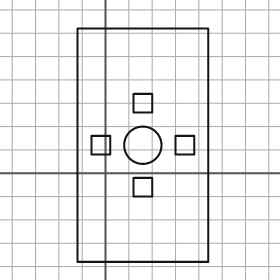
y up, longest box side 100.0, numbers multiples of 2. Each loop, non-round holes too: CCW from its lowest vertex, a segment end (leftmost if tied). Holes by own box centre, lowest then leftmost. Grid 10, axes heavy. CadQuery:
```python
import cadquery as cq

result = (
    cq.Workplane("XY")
    .moveTo(-12.0, -38.0)
    .lineTo(44.0, -38.0)
    .lineTo(44.0, 62.0)
    .lineTo(-12.0, 62.0)
    .close()
    .moveTo(12.0, -10.0)
    .lineTo(20.0, -10.0)
    .lineTo(20.0, -2.0)
    .lineTo(12.0, -2.0)
    .close()
    .moveTo(-6.0, 8.0)
    .lineTo(2.0, 8.0)
    .lineTo(2.0, 16.0)
    .lineTo(-6.0, 16.0)
    .close()
    .moveTo(16.0, 12.0)
    .circle(8.0)
    .moveTo(30.0, 8.0)
    .lineTo(38.0, 8.0)
    .lineTo(38.0, 16.0)
    .lineTo(30.0, 16.0)
    .close()
    .moveTo(12.0, 26.0)
    .lineTo(20.0, 26.0)
    .lineTo(20.0, 34.0)
    .lineTo(12.0, 34.0)
    .close()
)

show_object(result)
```